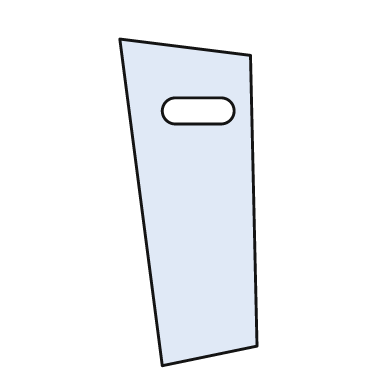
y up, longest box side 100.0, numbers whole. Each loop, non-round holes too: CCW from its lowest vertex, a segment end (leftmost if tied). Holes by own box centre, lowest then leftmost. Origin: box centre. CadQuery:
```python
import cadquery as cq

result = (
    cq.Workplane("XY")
    .moveTo(-8.0, -50.0)
    .lineTo(21.0, -44.0)
    .lineTo(19.0, 45.0)
    .lineTo(-21.0, 50.0)
    .close()
    .moveTo(-4.0, 24.0)
    .lineTo(10.0, 24.0)
    .threePointArc((14.0, 28.0), (10.0, 32.0))
    .lineTo(-4.0, 32.0)
    .threePointArc((-8.0, 28.0), (-4.0, 24.0))
    .close()
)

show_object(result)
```